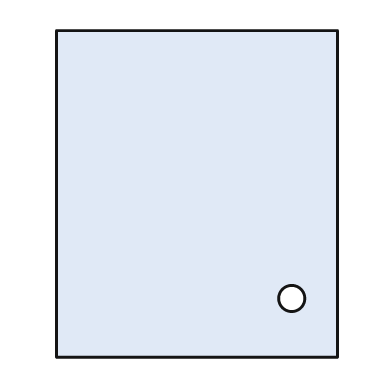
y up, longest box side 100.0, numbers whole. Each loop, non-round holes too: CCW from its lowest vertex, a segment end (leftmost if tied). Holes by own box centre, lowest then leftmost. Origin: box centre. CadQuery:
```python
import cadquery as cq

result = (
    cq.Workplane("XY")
    .moveTo(-43.0, -50.0)
    .lineTo(43.0, -50.0)
    .lineTo(43.0, 50.0)
    .lineTo(-43.0, 50.0)
    .close()
    .moveTo(29.0, -32.0)
    .circle(4.0)
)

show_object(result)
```